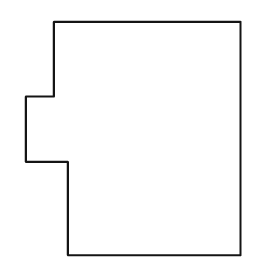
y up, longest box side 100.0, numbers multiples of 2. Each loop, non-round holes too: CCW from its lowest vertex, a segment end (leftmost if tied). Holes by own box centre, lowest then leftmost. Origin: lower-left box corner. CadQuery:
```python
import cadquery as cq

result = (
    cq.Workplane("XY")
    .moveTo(18.0, 0.0)
    .lineTo(92.0, 0.0)
    .lineTo(92.0, 100.0)
    .lineTo(12.0, 100.0)
    .lineTo(12.0, 68.0)
    .lineTo(0.0, 68.0)
    .lineTo(0.0, 40.0)
    .lineTo(18.0, 40.0)
    .close()
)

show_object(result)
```